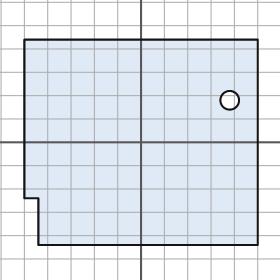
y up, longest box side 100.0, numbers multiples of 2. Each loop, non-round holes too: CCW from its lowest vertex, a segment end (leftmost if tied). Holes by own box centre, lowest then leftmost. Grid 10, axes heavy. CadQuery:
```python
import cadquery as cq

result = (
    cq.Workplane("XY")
    .moveTo(-44.0, -44.0)
    .lineTo(50.0, -44.0)
    .lineTo(50.0, 44.0)
    .lineTo(-50.0, 44.0)
    .lineTo(-50.0, -24.0)
    .lineTo(-44.0, -24.0)
    .close()
    .moveTo(38.0, 18.0)
    .circle(4.0)
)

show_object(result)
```